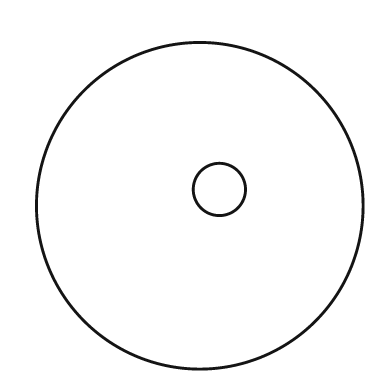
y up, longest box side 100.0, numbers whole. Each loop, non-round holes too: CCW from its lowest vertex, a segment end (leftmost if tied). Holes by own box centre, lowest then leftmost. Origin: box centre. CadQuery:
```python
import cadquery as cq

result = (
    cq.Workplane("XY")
    .moveTo(0.0, 0.0)
    .circle(50.0)
    .moveTo(6.0, 5.0)
    .circle(8.0)
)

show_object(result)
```